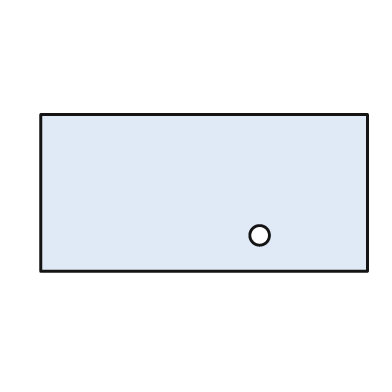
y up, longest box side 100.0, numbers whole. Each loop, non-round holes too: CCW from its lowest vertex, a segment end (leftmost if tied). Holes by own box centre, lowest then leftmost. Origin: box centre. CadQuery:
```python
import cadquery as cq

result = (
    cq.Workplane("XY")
    .moveTo(-50.0, -24.0)
    .lineTo(50.0, -24.0)
    .lineTo(50.0, 24.0)
    .lineTo(-50.0, 24.0)
    .close()
    .moveTo(17.0, -13.0)
    .circle(3.0)
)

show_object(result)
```